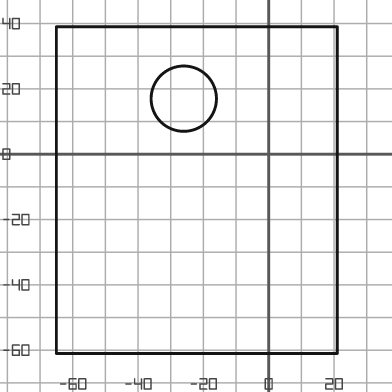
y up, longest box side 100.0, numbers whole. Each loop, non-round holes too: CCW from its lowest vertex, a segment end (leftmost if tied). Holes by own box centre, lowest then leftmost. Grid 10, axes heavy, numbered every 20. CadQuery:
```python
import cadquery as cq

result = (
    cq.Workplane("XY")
    .moveTo(-65.0, -61.0)
    .lineTo(21.0, -61.0)
    .lineTo(21.0, 39.0)
    .lineTo(-65.0, 39.0)
    .close()
    .moveTo(-26.0, 17.0)
    .circle(10.0)
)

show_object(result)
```